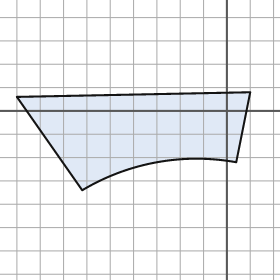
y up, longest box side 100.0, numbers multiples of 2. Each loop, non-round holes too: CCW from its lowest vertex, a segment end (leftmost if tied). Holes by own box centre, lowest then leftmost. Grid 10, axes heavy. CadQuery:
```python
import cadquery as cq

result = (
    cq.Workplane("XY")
    .moveTo(-62.0, -34.0)
    .threePointArc((-30.0, -22.0), (4.0, -22.0))
    .lineTo(10.0, 8.0)
    .lineTo(-90.0, 6.0)
    .close()
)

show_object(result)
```